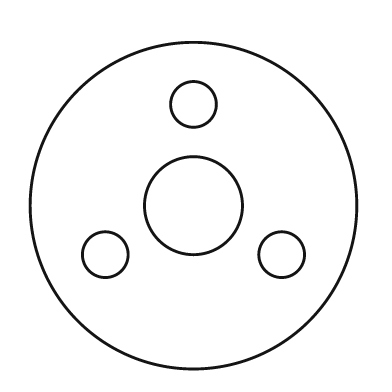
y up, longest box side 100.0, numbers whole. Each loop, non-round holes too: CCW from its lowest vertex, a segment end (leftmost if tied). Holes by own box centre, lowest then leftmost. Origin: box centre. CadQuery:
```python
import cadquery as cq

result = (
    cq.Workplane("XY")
    .moveTo(0.0, 0.0)
    .circle(50.0)
    .moveTo(-27.0, -15.0)
    .circle(7.0)
    .moveTo(27.0, -15.0)
    .circle(7.0)
    .moveTo(0.0, 0.0)
    .circle(15.0)
    .moveTo(0.0, 31.0)
    .circle(7.0)
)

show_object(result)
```